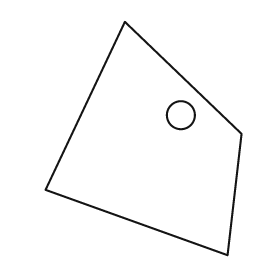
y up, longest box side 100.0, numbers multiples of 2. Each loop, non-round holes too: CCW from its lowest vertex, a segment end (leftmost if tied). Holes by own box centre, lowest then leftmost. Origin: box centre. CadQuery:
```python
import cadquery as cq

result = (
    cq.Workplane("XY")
    .moveTo(36.0, -50.0)
    .lineTo(42.0, 2.0)
    .lineTo(-8.0, 50.0)
    .lineTo(-42.0, -22.0)
    .close()
    .moveTo(16.0, 10.0)
    .circle(6.0)
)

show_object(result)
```